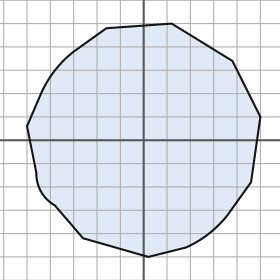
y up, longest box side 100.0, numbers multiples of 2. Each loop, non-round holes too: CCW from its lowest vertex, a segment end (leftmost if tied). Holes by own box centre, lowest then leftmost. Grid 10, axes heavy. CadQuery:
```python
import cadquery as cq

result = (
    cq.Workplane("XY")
    .moveTo(2.0, -50.0)
    .lineTo(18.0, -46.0)
    .threePointArc((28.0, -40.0), (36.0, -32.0))
    .lineTo(46.0, -18.0)
    .lineTo(50.0, 10.0)
    .lineTo(38.0, 34.0)
    .lineTo(12.0, 50.0)
    .lineTo(-16.0, 48.0)
    .lineTo(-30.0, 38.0)
    .threePointArc((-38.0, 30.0), (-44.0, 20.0))
    .lineTo(-50.0, 6.0)
    .lineTo(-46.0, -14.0)
    .threePointArc((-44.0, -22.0), (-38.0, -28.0))
    .lineTo(-26.0, -42.0)
    .close()
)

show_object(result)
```